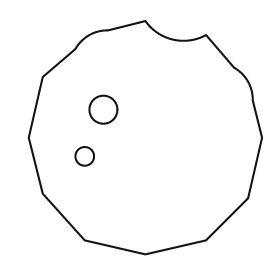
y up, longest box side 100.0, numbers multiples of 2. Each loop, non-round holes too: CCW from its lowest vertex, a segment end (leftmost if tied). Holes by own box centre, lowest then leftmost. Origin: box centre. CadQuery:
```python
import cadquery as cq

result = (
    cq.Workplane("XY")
    .moveTo(0.0, -50.0)
    .lineTo(26.0, -44.0)
    .lineTo(44.0, -26.0)
    .lineTo(50.0, 0.0)
    .lineTo(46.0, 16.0)
    .threePointArc((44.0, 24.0), (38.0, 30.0))
    .lineTo(26.0, 44.0)
    .threePointArc((12.0, 42.0), (0.0, 50.0))
    .lineTo(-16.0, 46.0)
    .threePointArc((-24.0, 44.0), (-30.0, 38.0))
    .lineTo(-44.0, 26.0)
    .lineTo(-50.0, 0.0)
    .lineTo(-44.0, -24.0)
    .lineTo(-26.0, -44.0)
    .close()
    .moveTo(-26.0, -8.0)
    .circle(4.0)
    .moveTo(-18.0, 12.0)
    .circle(6.0)
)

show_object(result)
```